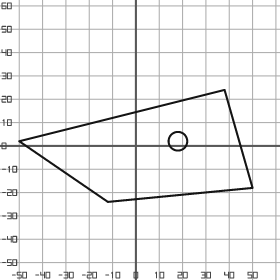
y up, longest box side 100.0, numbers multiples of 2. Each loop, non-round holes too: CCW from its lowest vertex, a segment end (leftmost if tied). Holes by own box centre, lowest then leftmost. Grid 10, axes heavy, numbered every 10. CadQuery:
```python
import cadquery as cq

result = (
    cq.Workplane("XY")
    .moveTo(-12.0, -24.0)
    .lineTo(50.0, -18.0)
    .lineTo(38.0, 24.0)
    .lineTo(-50.0, 2.0)
    .close()
    .moveTo(18.0, 2.0)
    .circle(4.0)
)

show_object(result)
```